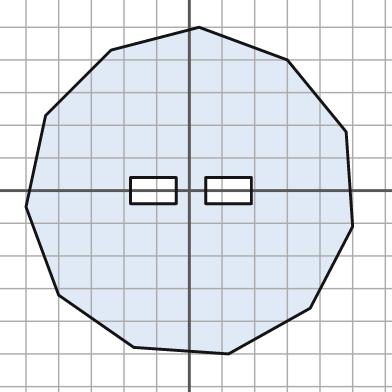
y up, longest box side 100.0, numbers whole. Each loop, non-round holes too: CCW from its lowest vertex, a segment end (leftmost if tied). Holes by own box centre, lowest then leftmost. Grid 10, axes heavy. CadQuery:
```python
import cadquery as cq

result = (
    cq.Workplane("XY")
    .moveTo(12.0, -50.0)
    .lineTo(37.0, -36.0)
    .lineTo(50.0, -11.0)
    .lineTo(48.0, 18.0)
    .lineTo(30.0, 40.0)
    .lineTo(3.0, 50.0)
    .lineTo(-24.0, 43.0)
    .lineTo(-44.0, 23.0)
    .lineTo(-50.0, -5.0)
    .lineTo(-40.0, -32.0)
    .lineTo(-17.0, -48.0)
    .close()
    .moveTo(-18.0, -4.0)
    .lineTo(-4.0, -4.0)
    .lineTo(-4.0, 4.0)
    .lineTo(-18.0, 4.0)
    .close()
    .moveTo(5.0, -4.0)
    .lineTo(19.0, -4.0)
    .lineTo(19.0, 4.0)
    .lineTo(5.0, 4.0)
    .close()
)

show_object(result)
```